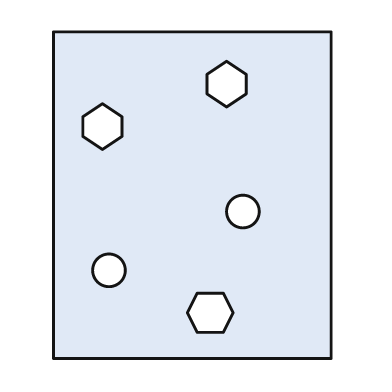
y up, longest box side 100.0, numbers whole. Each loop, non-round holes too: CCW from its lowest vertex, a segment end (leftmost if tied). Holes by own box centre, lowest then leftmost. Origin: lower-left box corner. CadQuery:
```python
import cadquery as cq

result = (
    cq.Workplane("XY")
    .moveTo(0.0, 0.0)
    .lineTo(85.0, 0.0)
    .lineTo(85.0, 100.0)
    .lineTo(0.0, 100.0)
    .close()
    .moveTo(44.0, 8.0)
    .lineTo(52.0, 8.0)
    .lineTo(55.0, 14.0)
    .lineTo(52.0, 20.0)
    .lineTo(44.0, 20.0)
    .lineTo(41.0, 14.0)
    .close()
    .moveTo(17.0, 27.0)
    .circle(5.0)
    .moveTo(58.0, 45.0)
    .circle(5.0)
    .moveTo(15.0, 64.0)
    .lineTo(21.0, 68.0)
    .lineTo(21.0, 74.0)
    .lineTo(15.0, 78.0)
    .lineTo(9.0, 74.0)
    .lineTo(9.0, 68.0)
    .close()
    .moveTo(53.0, 77.0)
    .lineTo(59.0, 81.0)
    .lineTo(59.0, 87.0)
    .lineTo(53.0, 91.0)
    .lineTo(47.0, 87.0)
    .lineTo(47.0, 81.0)
    .close()
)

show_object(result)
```